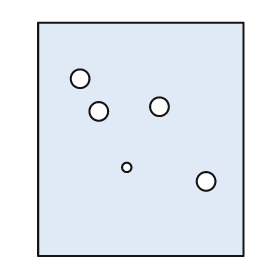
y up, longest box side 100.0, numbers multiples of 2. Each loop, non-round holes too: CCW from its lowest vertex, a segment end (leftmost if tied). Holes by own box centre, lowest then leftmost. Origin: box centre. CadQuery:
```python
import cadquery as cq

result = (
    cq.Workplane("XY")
    .moveTo(-44.0, -50.0)
    .lineTo(44.0, -50.0)
    .lineTo(44.0, 50.0)
    .lineTo(-44.0, 50.0)
    .close()
    .moveTo(28.0, -18.0)
    .circle(4.0)
    .moveTo(-6.0, -12.0)
    .circle(2.0)
    .moveTo(-18.0, 12.0)
    .circle(4.0)
    .moveTo(8.0, 14.0)
    .circle(4.0)
    .moveTo(-26.0, 26.0)
    .circle(4.0)
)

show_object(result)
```